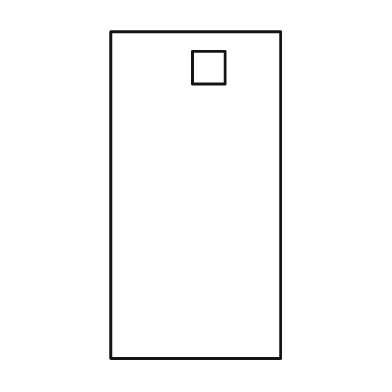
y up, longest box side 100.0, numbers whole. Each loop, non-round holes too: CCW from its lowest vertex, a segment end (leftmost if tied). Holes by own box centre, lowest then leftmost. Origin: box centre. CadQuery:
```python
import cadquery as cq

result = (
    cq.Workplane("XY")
    .moveTo(-26.0, -50.0)
    .lineTo(26.0, -50.0)
    .lineTo(26.0, 50.0)
    .lineTo(-26.0, 50.0)
    .close()
    .moveTo(-1.0, 34.0)
    .lineTo(9.0, 34.0)
    .lineTo(9.0, 44.0)
    .lineTo(-1.0, 44.0)
    .close()
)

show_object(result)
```